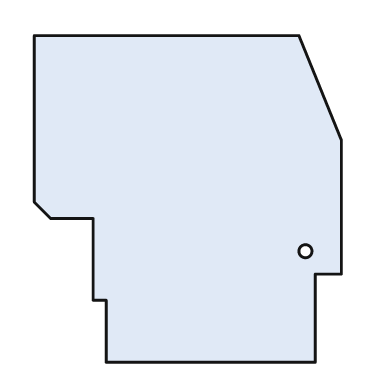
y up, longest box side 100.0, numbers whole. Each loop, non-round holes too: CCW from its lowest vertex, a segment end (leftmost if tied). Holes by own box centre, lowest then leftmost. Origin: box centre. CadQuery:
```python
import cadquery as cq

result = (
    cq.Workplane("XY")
    .moveTo(-25.0, -50.0)
    .lineTo(39.0, -50.0)
    .lineTo(39.0, -23.0)
    .lineTo(47.0, -23.0)
    .lineTo(47.0, 18.0)
    .lineTo(34.0, 50.0)
    .lineTo(-47.0, 50.0)
    .lineTo(-47.0, -1.0)
    .lineTo(-42.0, -6.0)
    .lineTo(-29.0, -6.0)
    .lineTo(-29.0, -31.0)
    .lineTo(-25.0, -31.0)
    .close()
    .moveTo(36.0, -16.0)
    .circle(2.0)
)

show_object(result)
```